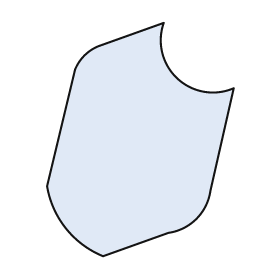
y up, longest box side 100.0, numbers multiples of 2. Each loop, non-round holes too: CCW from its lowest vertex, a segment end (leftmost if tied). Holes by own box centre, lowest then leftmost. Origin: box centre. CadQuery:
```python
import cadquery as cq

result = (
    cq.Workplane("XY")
    .moveTo(-16.0, -50.0)
    .lineTo(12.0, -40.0)
    .threePointArc((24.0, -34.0), (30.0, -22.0))
    .lineTo(40.0, 22.0)
    .threePointArc((16.0, 26.0), (10.0, 50.0))
    .lineTo(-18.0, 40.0)
    .threePointArc((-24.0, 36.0), (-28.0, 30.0))
    .lineTo(-40.0, -20.0)
    .threePointArc((-32.0, -38.0), (-16.0, -50.0))
    .close()
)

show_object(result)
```